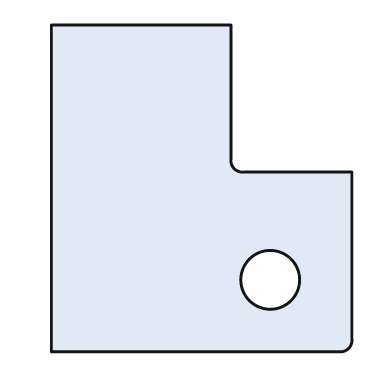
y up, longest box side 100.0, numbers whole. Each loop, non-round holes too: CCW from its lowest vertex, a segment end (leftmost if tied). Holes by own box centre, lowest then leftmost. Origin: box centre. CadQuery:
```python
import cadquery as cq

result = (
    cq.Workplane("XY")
    .moveTo(-46.0, -50.0)
    .lineTo(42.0, -50.0)
    .threePointArc((45.0, -49.0), (46.0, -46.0))
    .lineTo(46.0, 5.0)
    .lineTo(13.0, 5.0)
    .threePointArc((10.0, 6.0), (9.0, 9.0))
    .lineTo(9.0, 50.0)
    .lineTo(-46.0, 50.0)
    .close()
    .moveTo(21.0, -28.0)
    .circle(9.0)
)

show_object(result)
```